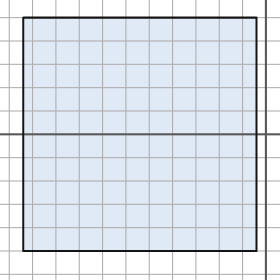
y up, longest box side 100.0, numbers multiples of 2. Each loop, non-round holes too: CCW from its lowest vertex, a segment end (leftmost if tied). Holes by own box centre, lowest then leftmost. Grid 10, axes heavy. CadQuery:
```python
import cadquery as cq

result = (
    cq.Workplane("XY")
    .moveTo(-104.0, -50.0)
    .lineTo(-4.0, -50.0)
    .lineTo(-4.0, 50.0)
    .lineTo(-104.0, 50.0)
    .close()
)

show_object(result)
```